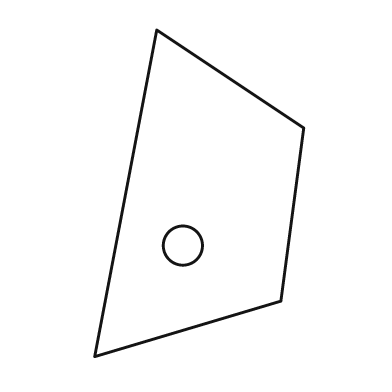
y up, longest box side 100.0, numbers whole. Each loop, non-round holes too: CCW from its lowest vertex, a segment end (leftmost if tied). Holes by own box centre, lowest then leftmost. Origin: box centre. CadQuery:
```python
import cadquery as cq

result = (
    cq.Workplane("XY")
    .moveTo(-32.0, -50.0)
    .lineTo(25.0, -33.0)
    .lineTo(32.0, 20.0)
    .lineTo(-13.0, 50.0)
    .close()
    .moveTo(-5.0, -16.0)
    .circle(6.0)
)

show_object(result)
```